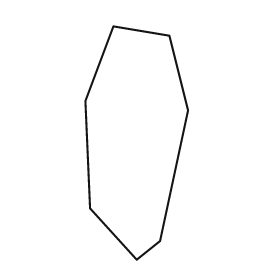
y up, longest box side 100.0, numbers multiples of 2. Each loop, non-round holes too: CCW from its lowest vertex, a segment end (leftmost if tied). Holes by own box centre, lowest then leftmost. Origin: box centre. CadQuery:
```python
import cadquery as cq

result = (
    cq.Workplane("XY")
    .moveTo(0.0, -50.0)
    .lineTo(10.0, -42.0)
    .lineTo(22.0, 14.0)
    .lineTo(14.0, 46.0)
    .lineTo(-10.0, 50.0)
    .lineTo(-22.0, 18.0)
    .lineTo(-20.0, -28.0)
    .close()
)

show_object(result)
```